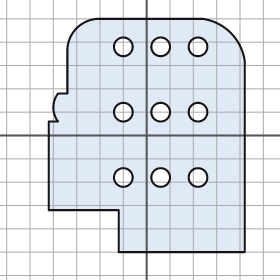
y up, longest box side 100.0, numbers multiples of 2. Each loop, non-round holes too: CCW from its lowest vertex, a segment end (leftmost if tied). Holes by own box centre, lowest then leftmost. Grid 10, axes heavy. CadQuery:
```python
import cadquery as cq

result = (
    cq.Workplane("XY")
    .moveTo(-12.0, -50.0)
    .lineTo(42.0, -50.0)
    .lineTo(42.0, 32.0)
    .threePointArc((36.0, 44.0), (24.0, 50.0))
    .lineTo(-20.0, 50.0)
    .threePointArc((-30.0, 46.0), (-34.0, 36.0))
    .lineTo(-34.0, 18.0)
    .lineTo(-38.0, 18.0)
    .threePointArc((-40.0, 12.0), (-38.0, 6.0))
    .lineTo(-42.0, 6.0)
    .lineTo(-42.0, -32.0)
    .lineTo(-12.0, -32.0)
    .close()
    .moveTo(-10.0, -18.0)
    .circle(4.0)
    .moveTo(6.0, -18.0)
    .circle(4.0)
    .moveTo(22.0, -18.0)
    .circle(4.0)
    .moveTo(-10.0, 10.0)
    .circle(4.0)
    .moveTo(6.0, 10.0)
    .circle(4.0)
    .moveTo(22.0, 10.0)
    .circle(4.0)
    .moveTo(-10.0, 38.0)
    .circle(4.0)
    .moveTo(6.0, 38.0)
    .circle(4.0)
    .moveTo(22.0, 38.0)
    .circle(4.0)
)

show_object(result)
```